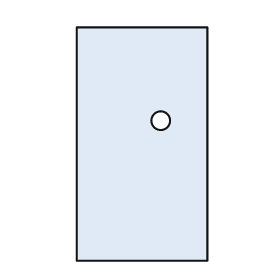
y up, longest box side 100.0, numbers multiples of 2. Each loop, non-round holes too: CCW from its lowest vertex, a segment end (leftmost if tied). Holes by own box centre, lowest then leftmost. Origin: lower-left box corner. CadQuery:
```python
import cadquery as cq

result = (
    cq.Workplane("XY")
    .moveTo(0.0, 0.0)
    .lineTo(56.0, 0.0)
    .lineTo(56.0, 100.0)
    .lineTo(0.0, 100.0)
    .close()
    .moveTo(36.0, 60.0)
    .circle(4.0)
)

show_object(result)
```